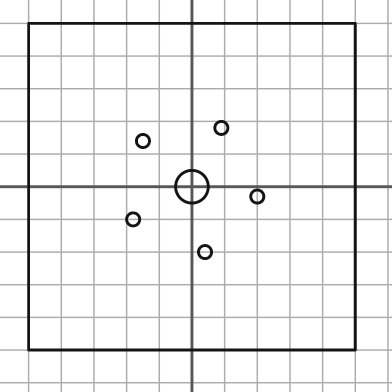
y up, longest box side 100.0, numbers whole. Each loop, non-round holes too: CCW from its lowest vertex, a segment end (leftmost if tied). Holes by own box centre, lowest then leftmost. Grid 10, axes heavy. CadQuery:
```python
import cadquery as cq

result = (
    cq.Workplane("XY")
    .moveTo(-50.0, -50.0)
    .lineTo(50.0, -50.0)
    .lineTo(50.0, 50.0)
    .lineTo(-50.0, 50.0)
    .close()
    .moveTo(4.0, -20.0)
    .circle(2.0)
    .moveTo(-18.0, -10.0)
    .circle(2.0)
    .moveTo(20.0, -3.0)
    .circle(2.0)
    .moveTo(0.0, 0.0)
    .circle(5.0)
    .moveTo(-15.0, 14.0)
    .circle(2.0)
    .moveTo(9.0, 18.0)
    .circle(2.0)
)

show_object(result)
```